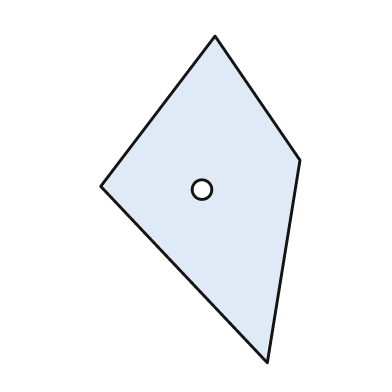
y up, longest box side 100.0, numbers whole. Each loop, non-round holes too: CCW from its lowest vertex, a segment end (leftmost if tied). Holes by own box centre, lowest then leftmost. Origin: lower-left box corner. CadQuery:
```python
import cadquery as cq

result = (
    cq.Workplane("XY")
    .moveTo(51.0, 0.0)
    .lineTo(61.0, 62.0)
    .lineTo(35.0, 100.0)
    .lineTo(0.0, 54.0)
    .close()
    .moveTo(31.0, 53.0)
    .circle(3.0)
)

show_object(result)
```